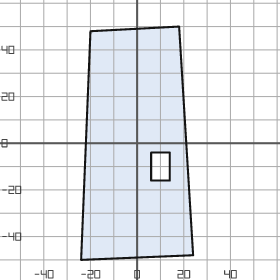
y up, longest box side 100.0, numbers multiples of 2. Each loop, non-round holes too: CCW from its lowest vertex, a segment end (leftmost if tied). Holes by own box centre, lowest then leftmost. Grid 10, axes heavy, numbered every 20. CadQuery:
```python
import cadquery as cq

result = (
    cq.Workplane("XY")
    .moveTo(-24.0, -50.0)
    .lineTo(24.0, -48.0)
    .lineTo(18.0, 50.0)
    .lineTo(-20.0, 48.0)
    .close()
    .moveTo(6.0, -16.0)
    .lineTo(14.0, -16.0)
    .lineTo(14.0, -4.0)
    .lineTo(6.0, -4.0)
    .close()
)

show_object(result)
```